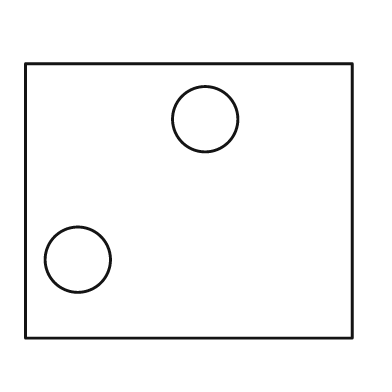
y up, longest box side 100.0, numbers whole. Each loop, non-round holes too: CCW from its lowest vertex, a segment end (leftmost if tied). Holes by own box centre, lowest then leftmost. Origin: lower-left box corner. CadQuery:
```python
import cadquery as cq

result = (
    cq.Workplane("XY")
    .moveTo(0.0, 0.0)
    .lineTo(100.0, 0.0)
    .lineTo(100.0, 84.0)
    .lineTo(0.0, 84.0)
    .close()
    .moveTo(16.0, 24.0)
    .circle(10.0)
    .moveTo(55.0, 67.0)
    .circle(10.0)
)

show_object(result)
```